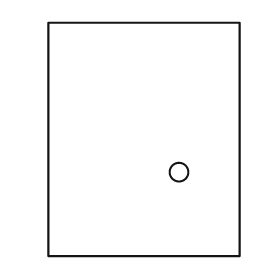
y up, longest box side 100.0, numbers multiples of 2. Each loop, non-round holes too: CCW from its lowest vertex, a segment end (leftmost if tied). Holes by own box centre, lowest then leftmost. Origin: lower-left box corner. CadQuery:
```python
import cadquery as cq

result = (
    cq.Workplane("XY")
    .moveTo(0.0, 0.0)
    .lineTo(82.0, 0.0)
    .lineTo(82.0, 100.0)
    .lineTo(0.0, 100.0)
    .close()
    .moveTo(56.0, 36.0)
    .circle(4.0)
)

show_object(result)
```